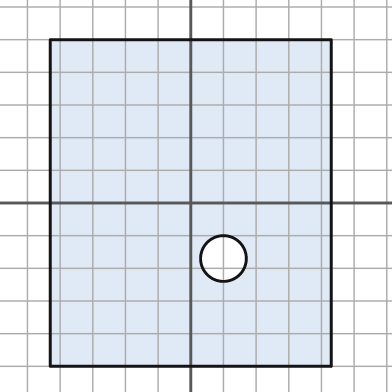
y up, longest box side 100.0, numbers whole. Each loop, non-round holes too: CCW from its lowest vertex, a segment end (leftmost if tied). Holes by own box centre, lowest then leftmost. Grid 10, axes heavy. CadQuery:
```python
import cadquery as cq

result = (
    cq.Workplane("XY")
    .moveTo(-43.0, -50.0)
    .lineTo(43.0, -50.0)
    .lineTo(43.0, 50.0)
    .lineTo(-43.0, 50.0)
    .close()
    .moveTo(10.0, -17.0)
    .circle(7.0)
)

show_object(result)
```